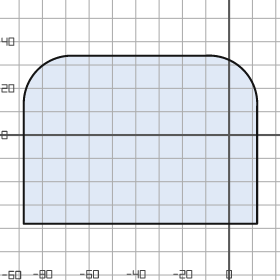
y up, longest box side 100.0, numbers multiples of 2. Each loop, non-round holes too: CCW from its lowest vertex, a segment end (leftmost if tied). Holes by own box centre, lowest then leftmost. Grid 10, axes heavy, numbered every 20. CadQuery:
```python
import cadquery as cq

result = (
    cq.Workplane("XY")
    .moveTo(-88.0, -38.0)
    .lineTo(12.0, -38.0)
    .lineTo(12.0, 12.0)
    .threePointArc((6.0, 28.0), (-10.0, 34.0))
    .lineTo(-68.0, 34.0)
    .threePointArc((-82.0, 28.0), (-88.0, 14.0))
    .close()
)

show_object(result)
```